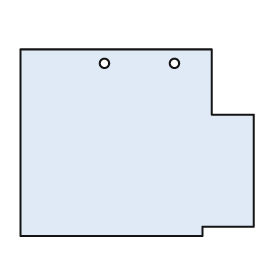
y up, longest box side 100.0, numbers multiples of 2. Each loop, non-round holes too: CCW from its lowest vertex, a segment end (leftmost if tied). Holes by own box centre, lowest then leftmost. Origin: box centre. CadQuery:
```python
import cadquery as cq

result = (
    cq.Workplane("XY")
    .moveTo(-50.0, -40.0)
    .lineTo(28.0, -40.0)
    .lineTo(28.0, -36.0)
    .lineTo(50.0, -36.0)
    .lineTo(50.0, 12.0)
    .lineTo(32.0, 12.0)
    .lineTo(32.0, 40.0)
    .lineTo(-50.0, 40.0)
    .close()
    .moveTo(-14.0, 34.0)
    .circle(2.0)
    .moveTo(16.0, 34.0)
    .circle(2.0)
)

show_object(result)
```